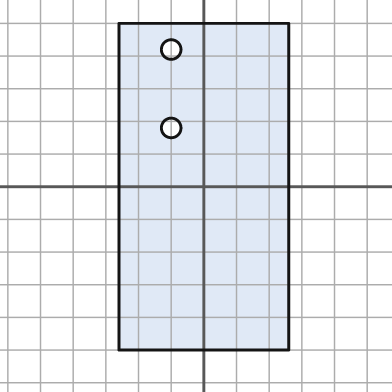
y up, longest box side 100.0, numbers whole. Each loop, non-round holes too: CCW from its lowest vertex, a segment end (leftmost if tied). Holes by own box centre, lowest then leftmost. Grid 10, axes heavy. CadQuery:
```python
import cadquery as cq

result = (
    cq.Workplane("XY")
    .moveTo(-26.0, -50.0)
    .lineTo(26.0, -50.0)
    .lineTo(26.0, 50.0)
    .lineTo(-26.0, 50.0)
    .close()
    .moveTo(-10.0, 18.0)
    .circle(3.0)
    .moveTo(-10.0, 42.0)
    .circle(3.0)
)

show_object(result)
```